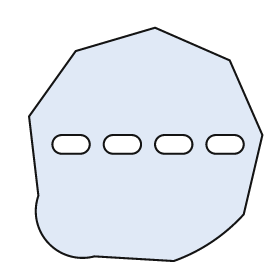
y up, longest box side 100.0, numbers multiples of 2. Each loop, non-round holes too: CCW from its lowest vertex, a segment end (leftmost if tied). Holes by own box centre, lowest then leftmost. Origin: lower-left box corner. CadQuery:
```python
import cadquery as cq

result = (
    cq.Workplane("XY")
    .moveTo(62.0, 0.0)
    .threePointArc((78.0, 8.0), (92.0, 20.0))
    .lineTo(100.0, 54.0)
    .lineTo(86.0, 86.0)
    .lineTo(54.0, 100.0)
    .lineTo(20.0, 90.0)
    .lineTo(0.0, 62.0)
    .lineTo(4.0, 28.0)
    .threePointArc((8.0, 8.0), (28.0, 2.0))
    .close()
    .moveTo(14.0, 46.0)
    .lineTo(22.0, 46.0)
    .threePointArc((26.0, 50.0), (22.0, 54.0))
    .lineTo(14.0, 54.0)
    .threePointArc((10.0, 50.0), (14.0, 46.0))
    .close()
    .moveTo(36.0, 46.0)
    .lineTo(44.0, 46.0)
    .threePointArc((48.0, 50.0), (44.0, 54.0))
    .lineTo(36.0, 54.0)
    .threePointArc((32.0, 50.0), (36.0, 46.0))
    .close()
    .moveTo(58.0, 46.0)
    .lineTo(66.0, 46.0)
    .threePointArc((70.0, 50.0), (66.0, 54.0))
    .lineTo(58.0, 54.0)
    .threePointArc((54.0, 50.0), (58.0, 46.0))
    .close()
    .moveTo(80.0, 46.0)
    .lineTo(88.0, 46.0)
    .threePointArc((92.0, 50.0), (88.0, 54.0))
    .lineTo(80.0, 54.0)
    .threePointArc((76.0, 50.0), (80.0, 46.0))
    .close()
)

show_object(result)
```